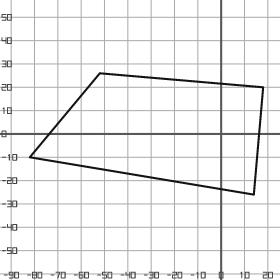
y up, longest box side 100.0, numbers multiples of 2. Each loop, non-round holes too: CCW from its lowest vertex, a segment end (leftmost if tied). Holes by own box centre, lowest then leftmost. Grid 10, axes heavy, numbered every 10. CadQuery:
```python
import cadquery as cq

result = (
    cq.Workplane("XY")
    .moveTo(14.0, -26.0)
    .lineTo(18.0, 20.0)
    .lineTo(-52.0, 26.0)
    .lineTo(-82.0, -10.0)
    .close()
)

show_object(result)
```